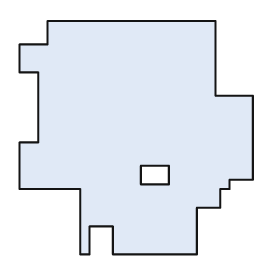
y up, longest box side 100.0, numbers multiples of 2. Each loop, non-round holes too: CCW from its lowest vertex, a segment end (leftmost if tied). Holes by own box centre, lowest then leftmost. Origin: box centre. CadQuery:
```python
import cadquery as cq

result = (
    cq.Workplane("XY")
    .moveTo(-24.0, -50.0)
    .lineTo(-20.0, -50.0)
    .lineTo(-20.0, -38.0)
    .lineTo(-10.0, -38.0)
    .lineTo(-10.0, -50.0)
    .lineTo(26.0, -50.0)
    .lineTo(26.0, -30.0)
    .lineTo(36.0, -30.0)
    .lineTo(36.0, -22.0)
    .lineTo(40.0, -22.0)
    .lineTo(40.0, -18.0)
    .lineTo(50.0, -18.0)
    .lineTo(50.0, 18.0)
    .lineTo(34.0, 18.0)
    .lineTo(34.0, 50.0)
    .lineTo(-38.0, 50.0)
    .lineTo(-38.0, 40.0)
    .lineTo(-50.0, 40.0)
    .lineTo(-50.0, 28.0)
    .lineTo(-42.0, 28.0)
    .lineTo(-42.0, -2.0)
    .lineTo(-50.0, -2.0)
    .lineTo(-50.0, -22.0)
    .lineTo(-24.0, -22.0)
    .close()
    .moveTo(2.0, -20.0)
    .lineTo(14.0, -20.0)
    .lineTo(14.0, -12.0)
    .lineTo(2.0, -12.0)
    .close()
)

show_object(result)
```